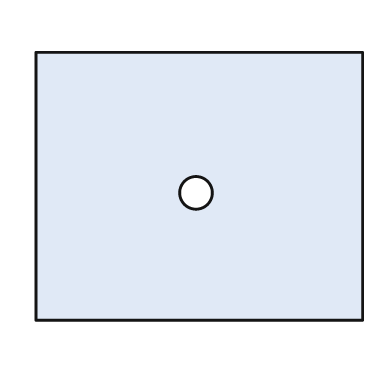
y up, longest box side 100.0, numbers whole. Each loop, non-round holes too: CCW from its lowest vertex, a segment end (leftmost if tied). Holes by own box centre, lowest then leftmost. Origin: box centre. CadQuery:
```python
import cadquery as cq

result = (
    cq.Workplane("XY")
    .moveTo(-50.0, -41.0)
    .lineTo(50.0, -41.0)
    .lineTo(50.0, 41.0)
    .lineTo(-50.0, 41.0)
    .close()
    .moveTo(-1.0, -2.0)
    .circle(5.0)
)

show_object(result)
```